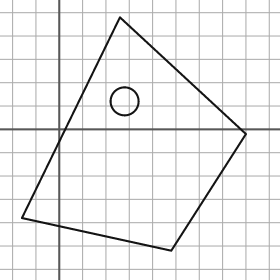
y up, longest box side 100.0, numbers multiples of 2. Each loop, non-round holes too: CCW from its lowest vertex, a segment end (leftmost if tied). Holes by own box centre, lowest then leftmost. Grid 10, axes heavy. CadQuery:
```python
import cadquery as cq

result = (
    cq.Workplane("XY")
    .moveTo(48.0, -52.0)
    .lineTo(80.0, -2.0)
    .lineTo(26.0, 48.0)
    .lineTo(-16.0, -38.0)
    .close()
    .moveTo(28.0, 12.0)
    .circle(6.0)
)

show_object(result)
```